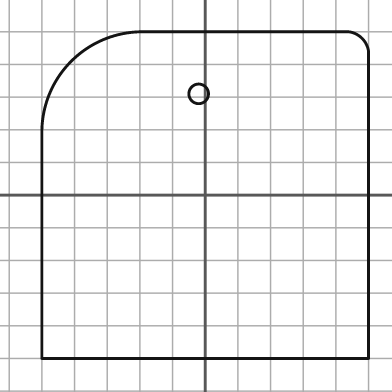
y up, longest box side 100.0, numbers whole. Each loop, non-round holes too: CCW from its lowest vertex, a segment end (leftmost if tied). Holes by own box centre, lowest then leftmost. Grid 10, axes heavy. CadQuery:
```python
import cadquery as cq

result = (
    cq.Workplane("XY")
    .moveTo(-50.0, -50.0)
    .lineTo(50.0, -50.0)
    .lineTo(50.0, 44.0)
    .threePointArc((48.0, 48.0), (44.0, 50.0))
    .lineTo(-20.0, 50.0)
    .threePointArc((-41.0, 41.0), (-50.0, 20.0))
    .close()
    .moveTo(-2.0, 31.0)
    .circle(3.0)
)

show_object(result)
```